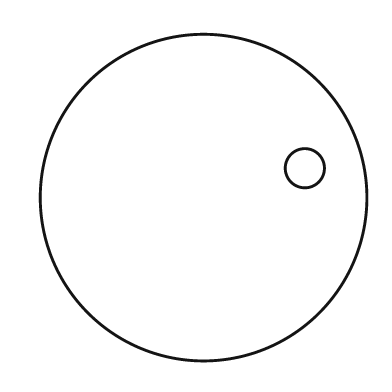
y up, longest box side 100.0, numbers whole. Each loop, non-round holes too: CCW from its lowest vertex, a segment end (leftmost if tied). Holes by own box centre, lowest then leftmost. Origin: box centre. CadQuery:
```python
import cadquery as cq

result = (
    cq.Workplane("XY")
    .moveTo(0.0, 0.0)
    .circle(50.0)
    .moveTo(31.0, 9.0)
    .circle(6.0)
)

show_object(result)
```